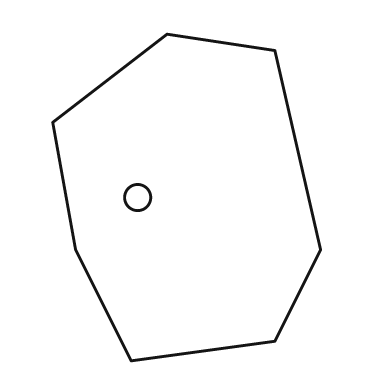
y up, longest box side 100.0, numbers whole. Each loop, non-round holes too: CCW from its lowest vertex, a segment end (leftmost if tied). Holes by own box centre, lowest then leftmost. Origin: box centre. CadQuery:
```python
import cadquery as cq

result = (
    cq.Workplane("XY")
    .moveTo(-17.0, -50.0)
    .lineTo(27.0, -44.0)
    .lineTo(41.0, -16.0)
    .lineTo(27.0, 45.0)
    .lineTo(-6.0, 50.0)
    .lineTo(-41.0, 23.0)
    .lineTo(-34.0, -16.0)
    .close()
    .moveTo(-15.0, 0.0)
    .circle(4.0)
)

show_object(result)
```